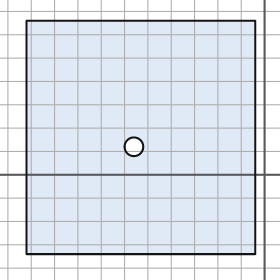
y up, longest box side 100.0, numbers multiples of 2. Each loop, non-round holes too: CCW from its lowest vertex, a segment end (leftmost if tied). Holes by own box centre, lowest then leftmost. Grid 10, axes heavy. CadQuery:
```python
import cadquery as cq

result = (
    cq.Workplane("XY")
    .moveTo(-102.0, -34.0)
    .lineTo(-4.0, -34.0)
    .lineTo(-4.0, 66.0)
    .lineTo(-102.0, 66.0)
    .close()
    .moveTo(-56.0, 12.0)
    .circle(4.0)
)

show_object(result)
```